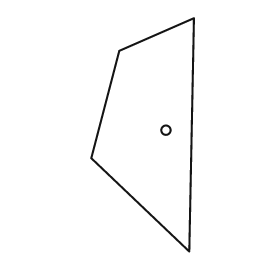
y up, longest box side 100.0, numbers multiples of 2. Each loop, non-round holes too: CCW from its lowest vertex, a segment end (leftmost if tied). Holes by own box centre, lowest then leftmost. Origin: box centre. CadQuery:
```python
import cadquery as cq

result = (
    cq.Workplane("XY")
    .moveTo(20.0, -50.0)
    .lineTo(22.0, 50.0)
    .lineTo(-10.0, 36.0)
    .lineTo(-22.0, -10.0)
    .close()
    .moveTo(10.0, 2.0)
    .circle(2.0)
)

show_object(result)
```